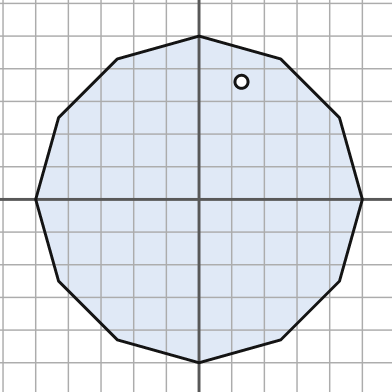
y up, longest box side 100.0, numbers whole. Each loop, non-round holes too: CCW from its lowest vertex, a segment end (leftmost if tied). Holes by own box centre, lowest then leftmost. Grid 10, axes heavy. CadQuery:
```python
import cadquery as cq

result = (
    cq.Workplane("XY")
    .moveTo(0.0, -50.0)
    .lineTo(25.0, -43.0)
    .lineTo(43.0, -25.0)
    .lineTo(50.0, 0.0)
    .lineTo(43.0, 25.0)
    .lineTo(25.0, 43.0)
    .lineTo(0.0, 50.0)
    .lineTo(-25.0, 43.0)
    .lineTo(-43.0, 25.0)
    .lineTo(-50.0, 0.0)
    .lineTo(-43.0, -25.0)
    .lineTo(-25.0, -43.0)
    .close()
    .moveTo(13.0, 36.0)
    .circle(2.0)
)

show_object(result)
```